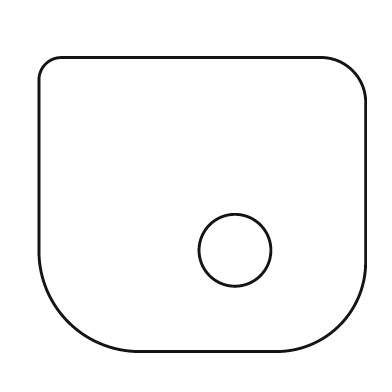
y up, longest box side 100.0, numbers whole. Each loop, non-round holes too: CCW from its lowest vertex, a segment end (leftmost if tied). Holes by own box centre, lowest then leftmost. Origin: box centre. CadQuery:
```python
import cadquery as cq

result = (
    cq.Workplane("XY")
    .moveTo(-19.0, -45.0)
    .lineTo(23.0, -45.0)
    .threePointArc((42.0, -37.0), (50.0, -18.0))
    .lineTo(50.0, 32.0)
    .threePointArc((46.0, 41.0), (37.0, 45.0))
    .lineTo(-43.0, 45.0)
    .threePointArc((-48.0, 43.0), (-50.0, 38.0))
    .lineTo(-50.0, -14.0)
    .threePointArc((-41.0, -36.0), (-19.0, -45.0))
    .close()
    .moveTo(10.0, -14.0)
    .circle(11.0)
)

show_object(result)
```